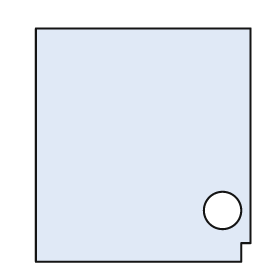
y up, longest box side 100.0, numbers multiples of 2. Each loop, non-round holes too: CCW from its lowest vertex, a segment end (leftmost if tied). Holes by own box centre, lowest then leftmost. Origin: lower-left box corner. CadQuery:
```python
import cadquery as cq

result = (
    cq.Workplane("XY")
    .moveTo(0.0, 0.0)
    .lineTo(88.0, 0.0)
    .lineTo(88.0, 8.0)
    .lineTo(92.0, 8.0)
    .lineTo(92.0, 100.0)
    .lineTo(0.0, 100.0)
    .close()
    .moveTo(80.0, 22.0)
    .circle(8.0)
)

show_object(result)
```